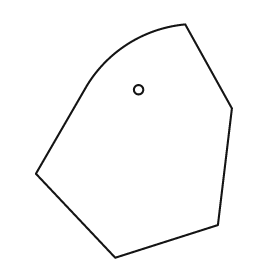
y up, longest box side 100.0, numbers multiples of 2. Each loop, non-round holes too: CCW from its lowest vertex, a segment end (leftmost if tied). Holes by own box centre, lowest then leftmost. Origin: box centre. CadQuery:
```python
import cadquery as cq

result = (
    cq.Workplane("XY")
    .moveTo(-8.0, -50.0)
    .lineTo(36.0, -36.0)
    .lineTo(42.0, 14.0)
    .lineTo(22.0, 50.0)
    .threePointArc((-2.0, 42.0), (-20.0, 24.0))
    .lineTo(-42.0, -14.0)
    .close()
    .moveTo(2.0, 22.0)
    .circle(2.0)
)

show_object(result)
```